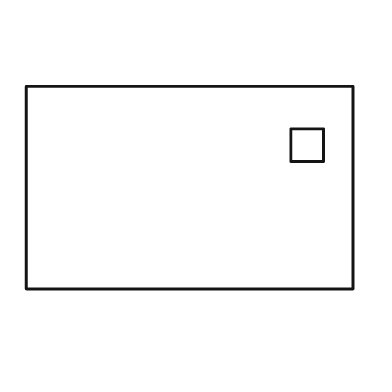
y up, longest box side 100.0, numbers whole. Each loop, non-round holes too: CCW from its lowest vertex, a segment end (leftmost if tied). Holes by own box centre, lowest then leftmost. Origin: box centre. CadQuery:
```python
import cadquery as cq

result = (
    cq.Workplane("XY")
    .moveTo(-50.0, -31.0)
    .lineTo(50.0, -31.0)
    .lineTo(50.0, 31.0)
    .lineTo(-50.0, 31.0)
    .close()
    .moveTo(31.0, 8.0)
    .lineTo(41.0, 8.0)
    .lineTo(41.0, 18.0)
    .lineTo(31.0, 18.0)
    .close()
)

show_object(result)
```